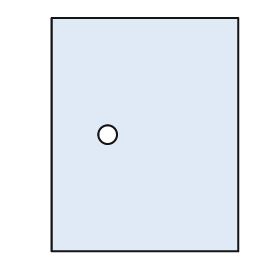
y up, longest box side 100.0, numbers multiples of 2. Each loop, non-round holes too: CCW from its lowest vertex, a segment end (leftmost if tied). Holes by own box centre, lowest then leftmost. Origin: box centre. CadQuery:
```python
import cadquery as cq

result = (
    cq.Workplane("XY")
    .moveTo(-40.0, -50.0)
    .lineTo(40.0, -50.0)
    .lineTo(40.0, 50.0)
    .lineTo(-40.0, 50.0)
    .close()
    .moveTo(-16.0, 0.0)
    .circle(4.0)
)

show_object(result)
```